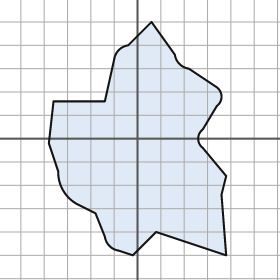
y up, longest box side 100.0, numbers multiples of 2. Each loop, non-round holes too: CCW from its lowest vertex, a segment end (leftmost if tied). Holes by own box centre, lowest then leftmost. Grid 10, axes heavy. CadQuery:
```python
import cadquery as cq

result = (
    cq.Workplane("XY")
    .moveTo(-2.0, -50.0)
    .lineTo(8.0, -40.0)
    .lineTo(38.0, -50.0)
    .lineTo(36.0, -24.0)
    .lineTo(38.0, -16.0)
    .lineTo(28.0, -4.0)
    .threePointArc((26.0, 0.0), (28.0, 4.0))
    .lineTo(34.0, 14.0)
    .threePointArc((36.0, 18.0), (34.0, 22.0))
    .lineTo(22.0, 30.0)
    .threePointArc((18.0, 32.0), (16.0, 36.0))
    .lineTo(6.0, 50.0)
    .lineTo(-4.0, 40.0)
    .threePointArc((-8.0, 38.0), (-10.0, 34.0))
    .lineTo(-14.0, 16.0)
    .lineTo(-36.0, 16.0)
    .lineTo(-38.0, -2.0)
    .lineTo(-34.0, -14.0)
    .threePointArc((-32.0, -22.0), (-26.0, -28.0))
    .lineTo(-18.0, -32.0)
    .lineTo(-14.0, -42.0)
    .threePointArc((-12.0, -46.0), (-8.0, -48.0))
    .close()
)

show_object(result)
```